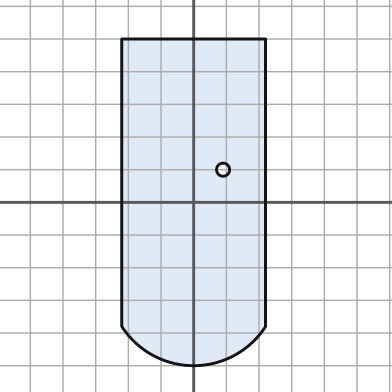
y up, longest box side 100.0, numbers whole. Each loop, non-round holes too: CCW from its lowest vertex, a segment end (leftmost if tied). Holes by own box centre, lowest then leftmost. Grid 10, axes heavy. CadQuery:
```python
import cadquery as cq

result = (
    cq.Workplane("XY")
    .moveTo(-22.0, -38.0)
    .threePointArc((0.0, -50.0), (22.0, -38.0))
    .lineTo(22.0, 50.0)
    .lineTo(-22.0, 50.0)
    .close()
    .moveTo(9.0, 10.0)
    .circle(2.0)
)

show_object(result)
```